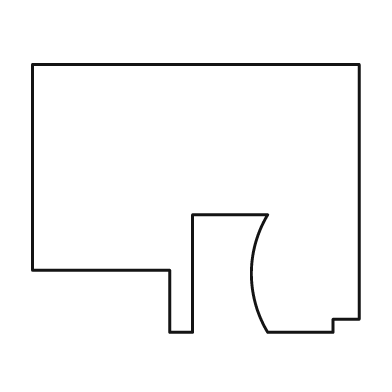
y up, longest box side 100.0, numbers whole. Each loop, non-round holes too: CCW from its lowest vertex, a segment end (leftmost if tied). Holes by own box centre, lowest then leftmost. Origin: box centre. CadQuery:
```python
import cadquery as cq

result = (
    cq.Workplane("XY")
    .moveTo(-8.0, -41.0)
    .lineTo(-1.0, -41.0)
    .lineTo(-1.0, -5.0)
    .lineTo(22.0, -5.0)
    .threePointArc((17.0, -23.0), (22.0, -41.0))
    .lineTo(42.0, -41.0)
    .lineTo(42.0, -37.0)
    .lineTo(50.0, -37.0)
    .lineTo(50.0, 41.0)
    .lineTo(-50.0, 41.0)
    .lineTo(-50.0, -22.0)
    .lineTo(-8.0, -22.0)
    .close()
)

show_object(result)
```